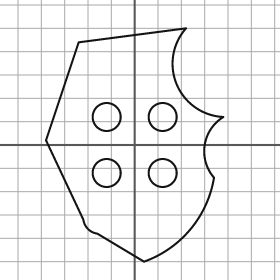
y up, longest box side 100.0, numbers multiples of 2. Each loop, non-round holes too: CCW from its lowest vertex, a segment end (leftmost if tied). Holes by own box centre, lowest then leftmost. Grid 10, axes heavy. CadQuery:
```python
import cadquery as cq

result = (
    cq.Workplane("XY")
    .moveTo(4.0, -50.0)
    .threePointArc((24.0, -36.0), (34.0, -14.0))
    .threePointArc((30.0, 0.0), (38.0, 12.0))
    .threePointArc((18.0, 26.0), (22.0, 50.0))
    .lineTo(-24.0, 44.0)
    .lineTo(-38.0, 2.0)
    .lineTo(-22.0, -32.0)
    .threePointArc((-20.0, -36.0), (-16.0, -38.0))
    .close()
    .moveTo(-12.0, -12.0)
    .circle(6.0)
    .moveTo(12.0, -12.0)
    .circle(6.0)
    .moveTo(-12.0, 12.0)
    .circle(6.0)
    .moveTo(12.0, 12.0)
    .circle(6.0)
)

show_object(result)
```